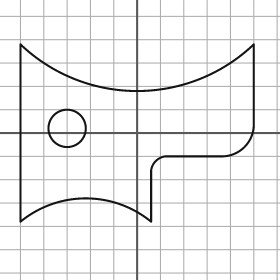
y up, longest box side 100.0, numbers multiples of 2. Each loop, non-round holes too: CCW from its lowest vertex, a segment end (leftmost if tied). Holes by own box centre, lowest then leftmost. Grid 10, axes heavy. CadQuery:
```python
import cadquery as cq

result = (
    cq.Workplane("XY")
    .moveTo(-50.0, -38.0)
    .threePointArc((-22.0, -28.0), (6.0, -38.0))
    .lineTo(6.0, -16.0)
    .threePointArc((8.0, -12.0), (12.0, -10.0))
    .lineTo(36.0, -10.0)
    .threePointArc((46.0, -6.0), (50.0, 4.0))
    .lineTo(50.0, 38.0)
    .threePointArc((0.0, 18.0), (-50.0, 38.0))
    .close()
    .moveTo(-30.0, 2.0)
    .circle(8.0)
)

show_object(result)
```